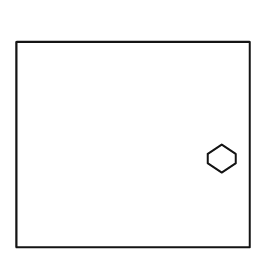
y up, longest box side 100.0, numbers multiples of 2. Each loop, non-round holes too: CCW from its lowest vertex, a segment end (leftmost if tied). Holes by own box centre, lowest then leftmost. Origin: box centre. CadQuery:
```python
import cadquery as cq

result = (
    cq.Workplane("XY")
    .moveTo(-50.0, -44.0)
    .lineTo(50.0, -44.0)
    .lineTo(50.0, 44.0)
    .lineTo(-50.0, 44.0)
    .close()
    .moveTo(38.0, -12.0)
    .lineTo(44.0, -8.0)
    .lineTo(44.0, -4.0)
    .lineTo(38.0, 0.0)
    .lineTo(32.0, -4.0)
    .lineTo(32.0, -8.0)
    .close()
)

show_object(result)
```